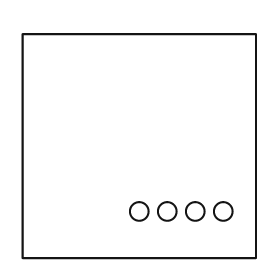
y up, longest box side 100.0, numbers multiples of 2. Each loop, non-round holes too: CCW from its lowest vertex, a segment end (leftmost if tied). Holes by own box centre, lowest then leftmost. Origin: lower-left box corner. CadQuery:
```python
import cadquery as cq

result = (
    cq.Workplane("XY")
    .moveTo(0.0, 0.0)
    .lineTo(100.0, 0.0)
    .lineTo(100.0, 96.0)
    .lineTo(0.0, 96.0)
    .close()
    .moveTo(50.0, 20.0)
    .circle(4.0)
    .moveTo(62.0, 20.0)
    .circle(4.0)
    .moveTo(74.0, 20.0)
    .circle(4.0)
    .moveTo(86.0, 20.0)
    .circle(4.0)
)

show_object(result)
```